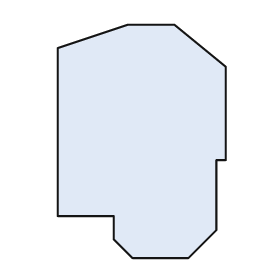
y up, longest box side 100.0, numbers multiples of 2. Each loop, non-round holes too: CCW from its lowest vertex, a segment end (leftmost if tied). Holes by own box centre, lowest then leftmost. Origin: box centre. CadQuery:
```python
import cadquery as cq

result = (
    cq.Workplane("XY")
    .moveTo(-4.0, -50.0)
    .lineTo(20.0, -50.0)
    .lineTo(32.0, -38.0)
    .lineTo(32.0, -8.0)
    .lineTo(36.0, -8.0)
    .lineTo(36.0, 32.0)
    .lineTo(14.0, 50.0)
    .lineTo(-6.0, 50.0)
    .lineTo(-36.0, 40.0)
    .lineTo(-36.0, -32.0)
    .lineTo(-12.0, -32.0)
    .lineTo(-12.0, -42.0)
    .close()
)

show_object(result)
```